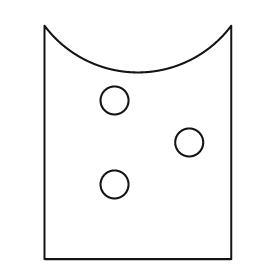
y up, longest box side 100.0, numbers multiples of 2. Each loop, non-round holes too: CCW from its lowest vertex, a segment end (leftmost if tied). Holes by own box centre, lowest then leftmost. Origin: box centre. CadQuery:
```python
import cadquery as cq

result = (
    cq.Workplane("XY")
    .moveTo(-40.0, -50.0)
    .lineTo(40.0, -50.0)
    .lineTo(40.0, 50.0)
    .threePointArc((0.0, 30.0), (-40.0, 50.0))
    .close()
    .moveTo(-10.0, -18.0)
    .circle(6.0)
    .moveTo(22.0, 0.0)
    .circle(6.0)
    .moveTo(-10.0, 18.0)
    .circle(6.0)
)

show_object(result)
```